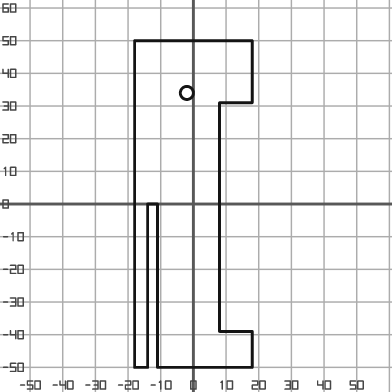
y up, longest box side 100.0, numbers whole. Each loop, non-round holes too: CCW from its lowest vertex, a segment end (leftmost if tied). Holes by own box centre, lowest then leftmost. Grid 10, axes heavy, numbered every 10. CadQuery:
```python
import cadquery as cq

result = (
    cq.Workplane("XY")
    .moveTo(-18.0, -50.0)
    .lineTo(-14.0, -50.0)
    .lineTo(-14.0, 0.0)
    .lineTo(-11.0, 0.0)
    .lineTo(-11.0, -50.0)
    .lineTo(18.0, -50.0)
    .lineTo(18.0, -39.0)
    .lineTo(8.0, -39.0)
    .lineTo(8.0, 31.0)
    .lineTo(18.0, 31.0)
    .lineTo(18.0, 50.0)
    .lineTo(-18.0, 50.0)
    .close()
    .moveTo(-2.0, 34.0)
    .circle(2.0)
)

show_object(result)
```